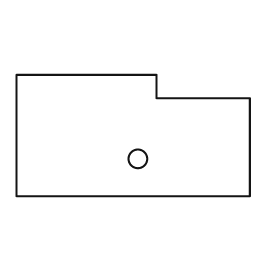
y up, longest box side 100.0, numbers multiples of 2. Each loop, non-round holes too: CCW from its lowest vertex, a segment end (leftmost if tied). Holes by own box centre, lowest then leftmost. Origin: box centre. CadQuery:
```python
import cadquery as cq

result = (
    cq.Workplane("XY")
    .moveTo(-50.0, -26.0)
    .lineTo(50.0, -26.0)
    .lineTo(50.0, 16.0)
    .lineTo(10.0, 16.0)
    .lineTo(10.0, 26.0)
    .lineTo(-50.0, 26.0)
    .close()
    .moveTo(2.0, -10.0)
    .circle(4.0)
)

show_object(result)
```